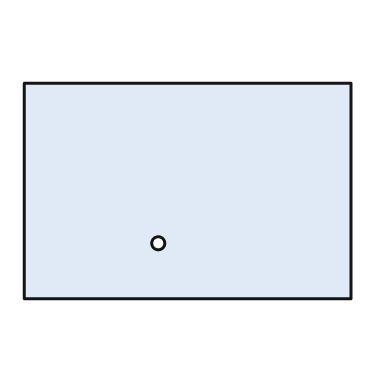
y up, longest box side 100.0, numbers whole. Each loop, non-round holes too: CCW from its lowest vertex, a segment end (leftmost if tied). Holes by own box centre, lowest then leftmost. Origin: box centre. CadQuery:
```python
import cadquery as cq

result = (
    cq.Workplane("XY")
    .moveTo(-50.0, -33.0)
    .lineTo(50.0, -33.0)
    .lineTo(50.0, 33.0)
    .lineTo(-50.0, 33.0)
    .close()
    .moveTo(-9.0, -16.0)
    .circle(2.0)
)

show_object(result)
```